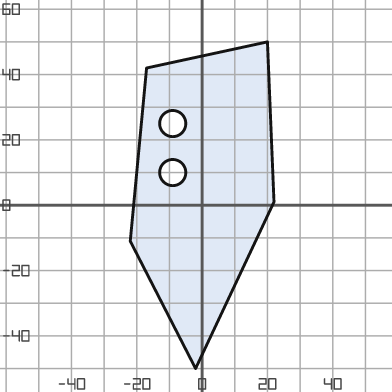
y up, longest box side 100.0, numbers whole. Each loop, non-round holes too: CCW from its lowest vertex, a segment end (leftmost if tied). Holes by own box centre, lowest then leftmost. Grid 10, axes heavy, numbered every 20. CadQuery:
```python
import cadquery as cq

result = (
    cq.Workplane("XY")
    .moveTo(-2.0, -50.0)
    .lineTo(22.0, 1.0)
    .lineTo(20.0, 50.0)
    .lineTo(-17.0, 42.0)
    .lineTo(-22.0, -11.0)
    .close()
    .moveTo(-9.0, 10.0)
    .circle(4.0)
    .moveTo(-9.0, 25.0)
    .circle(4.0)
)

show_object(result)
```